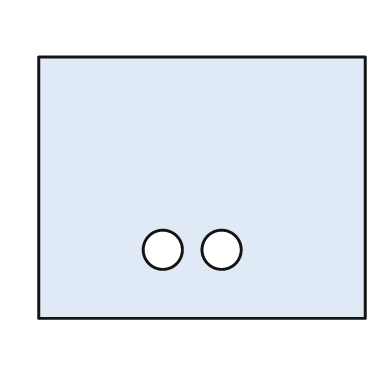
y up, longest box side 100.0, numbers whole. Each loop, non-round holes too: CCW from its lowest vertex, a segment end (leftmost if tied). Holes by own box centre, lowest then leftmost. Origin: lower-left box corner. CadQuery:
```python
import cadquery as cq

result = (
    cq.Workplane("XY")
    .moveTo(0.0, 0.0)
    .lineTo(100.0, 0.0)
    .lineTo(100.0, 80.0)
    .lineTo(0.0, 80.0)
    .close()
    .moveTo(38.0, 21.0)
    .circle(6.0)
    .moveTo(56.0, 21.0)
    .circle(6.0)
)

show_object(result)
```